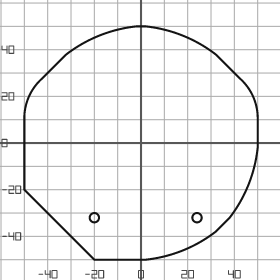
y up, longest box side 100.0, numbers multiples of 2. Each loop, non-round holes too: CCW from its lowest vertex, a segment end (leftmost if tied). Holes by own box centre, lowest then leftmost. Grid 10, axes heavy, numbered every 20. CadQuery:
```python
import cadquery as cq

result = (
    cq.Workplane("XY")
    .moveTo(-20.0, -50.0)
    .lineTo(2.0, -50.0)
    .threePointArc((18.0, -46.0), (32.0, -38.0))
    .lineTo(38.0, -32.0)
    .threePointArc((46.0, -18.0), (50.0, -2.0))
    .lineTo(50.0, 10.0)
    .threePointArc((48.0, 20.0), (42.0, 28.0))
    .lineTo(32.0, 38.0)
    .threePointArc((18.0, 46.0), (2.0, 50.0))
    .lineTo(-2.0, 50.0)
    .threePointArc((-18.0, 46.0), (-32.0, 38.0))
    .lineTo(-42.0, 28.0)
    .threePointArc((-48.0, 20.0), (-50.0, 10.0))
    .lineTo(-50.0, -20.0)
    .close()
    .moveTo(-20.0, -32.0)
    .circle(2.0)
    .moveTo(24.0, -32.0)
    .circle(2.0)
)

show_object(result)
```